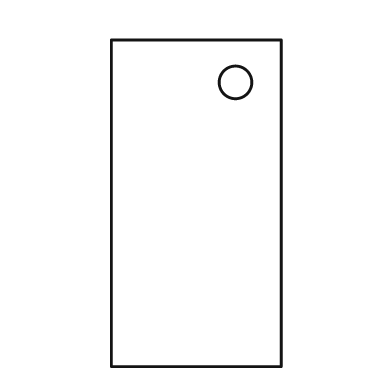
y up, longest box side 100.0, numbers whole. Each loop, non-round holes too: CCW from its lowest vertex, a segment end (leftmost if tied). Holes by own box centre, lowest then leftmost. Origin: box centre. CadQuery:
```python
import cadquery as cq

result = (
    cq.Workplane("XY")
    .moveTo(-26.0, -50.0)
    .lineTo(26.0, -50.0)
    .lineTo(26.0, 50.0)
    .lineTo(-26.0, 50.0)
    .close()
    .moveTo(12.0, 37.0)
    .circle(5.0)
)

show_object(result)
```